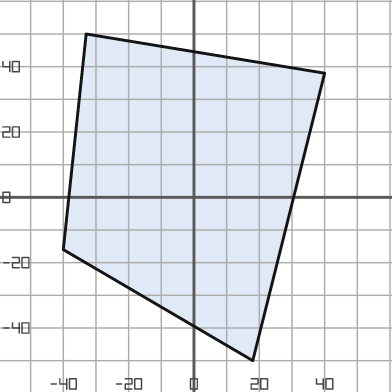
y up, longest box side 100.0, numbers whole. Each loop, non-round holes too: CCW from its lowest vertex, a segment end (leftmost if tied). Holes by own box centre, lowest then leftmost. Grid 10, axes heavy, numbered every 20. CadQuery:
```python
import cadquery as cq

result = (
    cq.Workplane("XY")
    .moveTo(18.0, -50.0)
    .lineTo(40.0, 38.0)
    .lineTo(-33.0, 50.0)
    .lineTo(-40.0, -16.0)
    .close()
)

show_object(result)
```